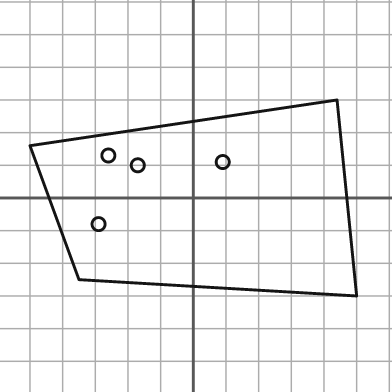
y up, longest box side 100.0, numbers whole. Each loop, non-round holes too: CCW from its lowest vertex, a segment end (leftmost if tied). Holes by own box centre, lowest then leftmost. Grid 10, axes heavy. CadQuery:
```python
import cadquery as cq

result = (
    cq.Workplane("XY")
    .moveTo(50.0, -30.0)
    .lineTo(44.0, 30.0)
    .lineTo(-50.0, 16.0)
    .lineTo(-35.0, -25.0)
    .close()
    .moveTo(-29.0, -8.0)
    .circle(2.0)
    .moveTo(-17.0, 10.0)
    .circle(2.0)
    .moveTo(9.0, 11.0)
    .circle(2.0)
    .moveTo(-26.0, 13.0)
    .circle(2.0)
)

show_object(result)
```